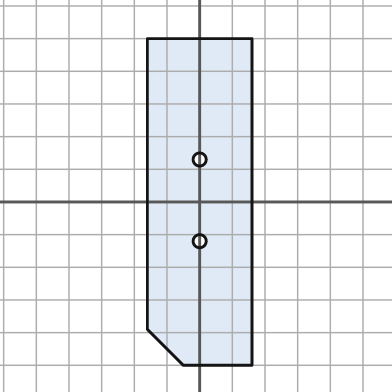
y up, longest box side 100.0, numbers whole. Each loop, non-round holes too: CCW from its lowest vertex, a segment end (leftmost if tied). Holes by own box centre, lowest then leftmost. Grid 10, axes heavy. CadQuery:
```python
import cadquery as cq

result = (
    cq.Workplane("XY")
    .moveTo(-5.0, -50.0)
    .lineTo(16.0, -50.0)
    .lineTo(16.0, 50.0)
    .lineTo(-16.0, 50.0)
    .lineTo(-16.0, -39.0)
    .close()
    .moveTo(0.0, -12.0)
    .circle(2.0)
    .moveTo(0.0, 13.0)
    .circle(2.0)
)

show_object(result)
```